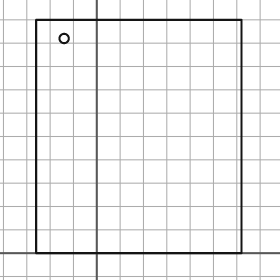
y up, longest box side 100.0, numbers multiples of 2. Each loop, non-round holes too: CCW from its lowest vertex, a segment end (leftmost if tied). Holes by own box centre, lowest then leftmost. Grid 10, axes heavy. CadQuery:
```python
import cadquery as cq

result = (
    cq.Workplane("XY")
    .moveTo(-26.0, 0.0)
    .lineTo(62.0, 0.0)
    .lineTo(62.0, 100.0)
    .lineTo(-26.0, 100.0)
    .close()
    .moveTo(-14.0, 92.0)
    .circle(2.0)
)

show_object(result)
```